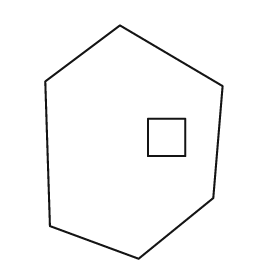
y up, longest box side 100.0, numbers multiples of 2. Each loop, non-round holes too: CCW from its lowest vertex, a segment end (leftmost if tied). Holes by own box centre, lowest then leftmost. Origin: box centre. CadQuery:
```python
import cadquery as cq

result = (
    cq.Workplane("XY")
    .moveTo(2.0, -50.0)
    .lineTo(34.0, -24.0)
    .lineTo(38.0, 24.0)
    .lineTo(-6.0, 50.0)
    .lineTo(-38.0, 26.0)
    .lineTo(-36.0, -36.0)
    .close()
    .moveTo(6.0, -6.0)
    .lineTo(22.0, -6.0)
    .lineTo(22.0, 10.0)
    .lineTo(6.0, 10.0)
    .close()
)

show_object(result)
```